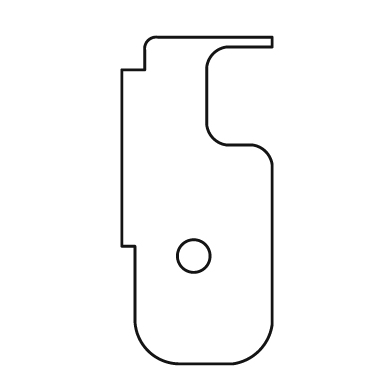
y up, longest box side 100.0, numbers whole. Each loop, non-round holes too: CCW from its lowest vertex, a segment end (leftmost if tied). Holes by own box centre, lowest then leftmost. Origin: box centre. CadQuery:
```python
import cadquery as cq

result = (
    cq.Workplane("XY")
    .moveTo(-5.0, -50.0)
    .lineTo(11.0, -50.0)
    .threePointArc((19.0, -46.0), (23.0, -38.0))
    .lineTo(23.0, 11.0)
    .threePointArc((21.0, 15.0), (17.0, 17.0))
    .lineTo(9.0, 17.0)
    .threePointArc((5.0, 19.0), (3.0, 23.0))
    .lineTo(3.0, 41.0)
    .threePointArc((5.0, 45.0), (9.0, 47.0))
    .lineTo(23.0, 47.0)
    .lineTo(23.0, 50.0)
    .lineTo(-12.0, 50.0)
    .threePointArc((-15.0, 49.0), (-16.0, 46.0))
    .lineTo(-16.0, 40.0)
    .lineTo(-23.0, 40.0)
    .lineTo(-23.0, -14.0)
    .lineTo(-19.0, -14.0)
    .lineTo(-19.0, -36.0)
    .threePointArc((-15.0, -46.0), (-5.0, -50.0))
    .close()
    .moveTo(-1.0, -17.0)
    .circle(5.0)
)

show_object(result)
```